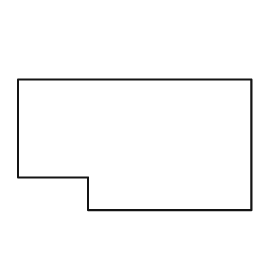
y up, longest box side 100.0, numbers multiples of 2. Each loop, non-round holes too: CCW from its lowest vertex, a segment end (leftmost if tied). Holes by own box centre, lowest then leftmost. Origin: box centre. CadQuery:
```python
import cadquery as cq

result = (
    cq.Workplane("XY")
    .moveTo(-20.0, -28.0)
    .lineTo(50.0, -28.0)
    .lineTo(50.0, 28.0)
    .lineTo(-50.0, 28.0)
    .lineTo(-50.0, -14.0)
    .lineTo(-20.0, -14.0)
    .close()
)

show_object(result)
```